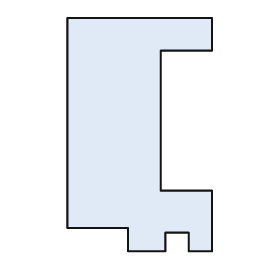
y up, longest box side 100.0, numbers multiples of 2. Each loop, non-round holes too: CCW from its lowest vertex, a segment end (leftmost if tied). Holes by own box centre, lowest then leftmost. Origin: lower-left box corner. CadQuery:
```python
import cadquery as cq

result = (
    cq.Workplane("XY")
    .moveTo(26.0, 0.0)
    .lineTo(42.0, 0.0)
    .lineTo(42.0, 8.0)
    .lineTo(52.0, 8.0)
    .lineTo(52.0, 0.0)
    .lineTo(62.0, 0.0)
    .lineTo(62.0, 26.0)
    .lineTo(40.0, 26.0)
    .lineTo(40.0, 86.0)
    .lineTo(62.0, 86.0)
    .lineTo(62.0, 100.0)
    .lineTo(0.0, 100.0)
    .lineTo(0.0, 10.0)
    .lineTo(26.0, 10.0)
    .close()
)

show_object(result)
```